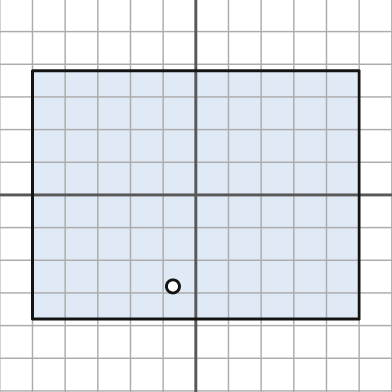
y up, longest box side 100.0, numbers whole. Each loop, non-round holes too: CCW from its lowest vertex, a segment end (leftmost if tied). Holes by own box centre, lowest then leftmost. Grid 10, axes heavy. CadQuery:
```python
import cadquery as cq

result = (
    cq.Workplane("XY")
    .moveTo(-50.0, -38.0)
    .lineTo(50.0, -38.0)
    .lineTo(50.0, 38.0)
    .lineTo(-50.0, 38.0)
    .close()
    .moveTo(-7.0, -28.0)
    .circle(2.0)
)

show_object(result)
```